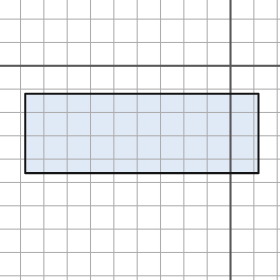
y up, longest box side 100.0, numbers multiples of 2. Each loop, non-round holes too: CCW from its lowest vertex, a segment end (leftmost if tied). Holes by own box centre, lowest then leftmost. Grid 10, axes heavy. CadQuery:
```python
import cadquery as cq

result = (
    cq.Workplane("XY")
    .moveTo(-88.0, -46.0)
    .lineTo(12.0, -46.0)
    .lineTo(12.0, -12.0)
    .lineTo(-88.0, -12.0)
    .close()
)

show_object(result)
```